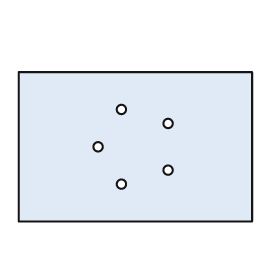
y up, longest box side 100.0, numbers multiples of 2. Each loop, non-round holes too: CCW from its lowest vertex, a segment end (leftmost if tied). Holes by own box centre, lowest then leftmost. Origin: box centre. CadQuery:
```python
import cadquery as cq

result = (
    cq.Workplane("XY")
    .moveTo(-50.0, -32.0)
    .lineTo(50.0, -32.0)
    .lineTo(50.0, 32.0)
    .lineTo(-50.0, 32.0)
    .close()
    .moveTo(-6.0, -16.0)
    .circle(2.0)
    .moveTo(14.0, -10.0)
    .circle(2.0)
    .moveTo(-16.0, 0.0)
    .circle(2.0)
    .moveTo(14.0, 10.0)
    .circle(2.0)
    .moveTo(-6.0, 16.0)
    .circle(2.0)
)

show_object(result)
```